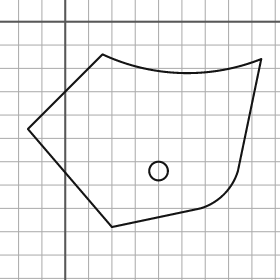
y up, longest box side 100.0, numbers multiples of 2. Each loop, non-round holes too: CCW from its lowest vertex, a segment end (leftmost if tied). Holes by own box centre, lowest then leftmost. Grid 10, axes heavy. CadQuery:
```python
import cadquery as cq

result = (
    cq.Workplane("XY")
    .moveTo(20.0, -88.0)
    .lineTo(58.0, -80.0)
    .threePointArc((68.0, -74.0), (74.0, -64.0))
    .lineTo(84.0, -16.0)
    .threePointArc((50.0, -22.0), (16.0, -14.0))
    .lineTo(-16.0, -46.0)
    .close()
    .moveTo(40.0, -64.0)
    .circle(4.0)
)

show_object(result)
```